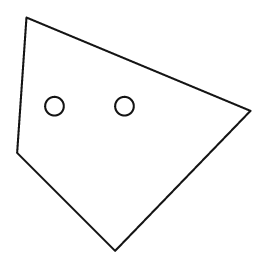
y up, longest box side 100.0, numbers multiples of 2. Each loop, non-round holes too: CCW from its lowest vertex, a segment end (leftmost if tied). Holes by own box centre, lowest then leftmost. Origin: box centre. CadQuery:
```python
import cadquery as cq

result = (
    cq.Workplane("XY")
    .moveTo(-8.0, -50.0)
    .lineTo(50.0, 10.0)
    .lineTo(-46.0, 50.0)
    .lineTo(-50.0, -8.0)
    .close()
    .moveTo(-34.0, 12.0)
    .circle(4.0)
    .moveTo(-4.0, 12.0)
    .circle(4.0)
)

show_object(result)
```